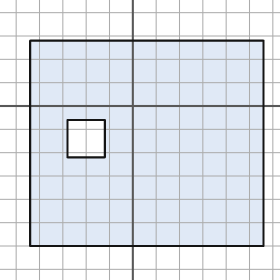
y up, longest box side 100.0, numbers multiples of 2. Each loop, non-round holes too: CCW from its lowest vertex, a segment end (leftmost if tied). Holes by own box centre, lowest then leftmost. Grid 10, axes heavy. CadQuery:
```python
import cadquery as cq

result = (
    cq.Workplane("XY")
    .moveTo(-44.0, -60.0)
    .lineTo(56.0, -60.0)
    .lineTo(56.0, 28.0)
    .lineTo(-44.0, 28.0)
    .close()
    .moveTo(-28.0, -22.0)
    .lineTo(-12.0, -22.0)
    .lineTo(-12.0, -6.0)
    .lineTo(-28.0, -6.0)
    .close()
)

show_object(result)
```